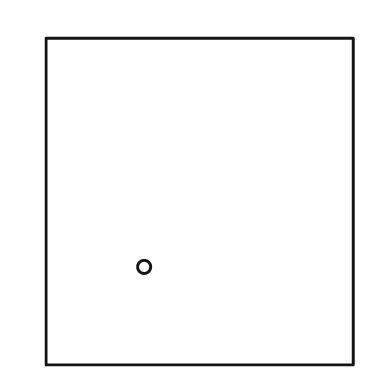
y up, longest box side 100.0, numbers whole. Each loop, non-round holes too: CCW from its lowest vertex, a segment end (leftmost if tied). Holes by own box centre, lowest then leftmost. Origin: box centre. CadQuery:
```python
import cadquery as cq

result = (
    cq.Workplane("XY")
    .moveTo(-47.0, -50.0)
    .lineTo(47.0, -50.0)
    .lineTo(47.0, 50.0)
    .lineTo(-47.0, 50.0)
    .close()
    .moveTo(-17.0, -20.0)
    .circle(2.0)
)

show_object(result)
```